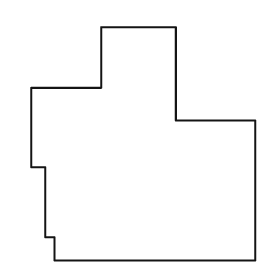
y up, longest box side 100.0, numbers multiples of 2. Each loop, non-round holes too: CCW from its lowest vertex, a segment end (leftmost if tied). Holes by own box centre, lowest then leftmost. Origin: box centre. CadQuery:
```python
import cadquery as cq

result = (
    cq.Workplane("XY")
    .moveTo(-38.0, -50.0)
    .lineTo(48.0, -50.0)
    .lineTo(48.0, 10.0)
    .lineTo(14.0, 10.0)
    .lineTo(14.0, 50.0)
    .lineTo(-18.0, 50.0)
    .lineTo(-18.0, 24.0)
    .lineTo(-48.0, 24.0)
    .lineTo(-48.0, -10.0)
    .lineTo(-42.0, -10.0)
    .lineTo(-42.0, -40.0)
    .lineTo(-38.0, -40.0)
    .close()
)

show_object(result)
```